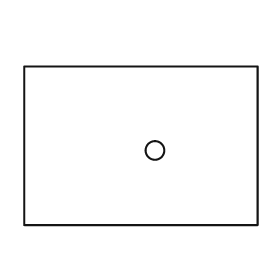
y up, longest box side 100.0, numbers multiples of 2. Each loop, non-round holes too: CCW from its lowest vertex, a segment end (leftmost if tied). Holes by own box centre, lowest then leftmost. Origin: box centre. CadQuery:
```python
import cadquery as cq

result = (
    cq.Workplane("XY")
    .moveTo(-50.0, -34.0)
    .lineTo(50.0, -34.0)
    .lineTo(50.0, 34.0)
    .lineTo(-50.0, 34.0)
    .close()
    .moveTo(6.0, -2.0)
    .circle(4.0)
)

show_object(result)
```